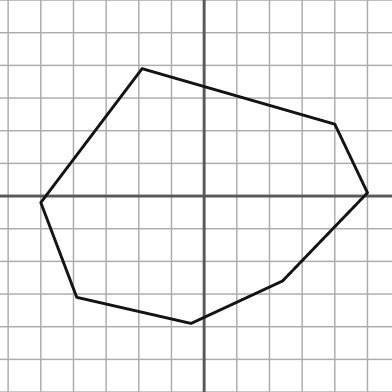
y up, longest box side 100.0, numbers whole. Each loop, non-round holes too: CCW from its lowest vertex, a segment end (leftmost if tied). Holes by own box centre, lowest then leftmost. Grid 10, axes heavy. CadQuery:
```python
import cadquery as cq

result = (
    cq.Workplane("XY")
    .moveTo(-4.0, -39.0)
    .lineTo(24.0, -26.0)
    .lineTo(50.0, 1.0)
    .lineTo(40.0, 22.0)
    .lineTo(-19.0, 39.0)
    .lineTo(-50.0, -2.0)
    .lineTo(-39.0, -31.0)
    .close()
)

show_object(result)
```